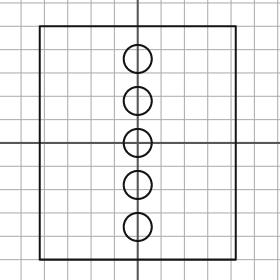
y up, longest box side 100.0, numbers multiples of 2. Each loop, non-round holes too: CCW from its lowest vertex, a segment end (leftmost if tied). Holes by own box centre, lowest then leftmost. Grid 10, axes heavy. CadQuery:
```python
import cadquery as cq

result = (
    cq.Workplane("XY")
    .moveTo(-42.0, -50.0)
    .lineTo(42.0, -50.0)
    .lineTo(42.0, 50.0)
    .lineTo(-42.0, 50.0)
    .close()
    .moveTo(0.0, -36.0)
    .circle(6.0)
    .moveTo(0.0, -18.0)
    .circle(6.0)
    .moveTo(0.0, 0.0)
    .circle(6.0)
    .moveTo(0.0, 18.0)
    .circle(6.0)
    .moveTo(0.0, 36.0)
    .circle(6.0)
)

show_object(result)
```